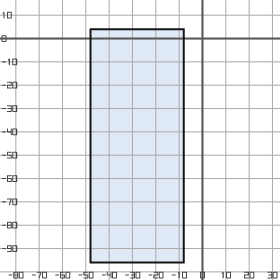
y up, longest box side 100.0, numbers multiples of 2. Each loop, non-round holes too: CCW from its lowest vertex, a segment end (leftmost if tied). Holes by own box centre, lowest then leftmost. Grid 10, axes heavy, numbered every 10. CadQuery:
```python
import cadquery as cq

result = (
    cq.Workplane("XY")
    .moveTo(-48.0, -96.0)
    .lineTo(-8.0, -96.0)
    .lineTo(-8.0, 4.0)
    .lineTo(-48.0, 4.0)
    .close()
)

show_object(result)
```